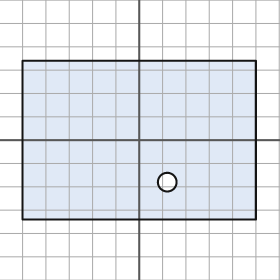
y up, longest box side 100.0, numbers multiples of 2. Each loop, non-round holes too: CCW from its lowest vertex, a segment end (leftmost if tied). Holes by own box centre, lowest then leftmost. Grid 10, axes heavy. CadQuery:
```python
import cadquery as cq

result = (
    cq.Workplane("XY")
    .moveTo(-50.0, -34.0)
    .lineTo(50.0, -34.0)
    .lineTo(50.0, 34.0)
    .lineTo(-50.0, 34.0)
    .close()
    .moveTo(12.0, -18.0)
    .circle(4.0)
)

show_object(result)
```